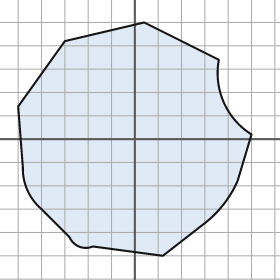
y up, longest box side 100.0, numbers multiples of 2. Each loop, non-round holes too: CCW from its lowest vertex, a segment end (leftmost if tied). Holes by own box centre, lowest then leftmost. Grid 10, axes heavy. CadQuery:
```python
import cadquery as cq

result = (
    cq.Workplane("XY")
    .moveTo(12.0, -50.0)
    .lineTo(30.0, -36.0)
    .threePointArc((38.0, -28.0), (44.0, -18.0))
    .lineTo(50.0, 2.0)
    .threePointArc((38.0, 16.0), (36.0, 34.0))
    .lineTo(4.0, 50.0)
    .lineTo(-30.0, 42.0)
    .lineTo(-50.0, 14.0)
    .lineTo(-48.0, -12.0)
    .threePointArc((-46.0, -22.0), (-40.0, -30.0))
    .lineTo(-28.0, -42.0)
    .threePointArc((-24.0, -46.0), (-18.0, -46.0))
    .close()
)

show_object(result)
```